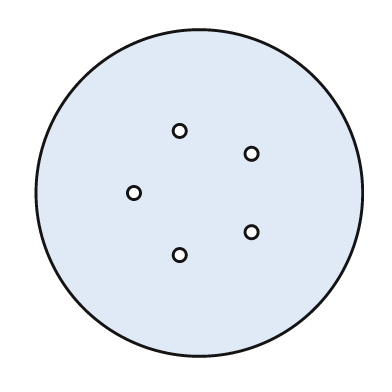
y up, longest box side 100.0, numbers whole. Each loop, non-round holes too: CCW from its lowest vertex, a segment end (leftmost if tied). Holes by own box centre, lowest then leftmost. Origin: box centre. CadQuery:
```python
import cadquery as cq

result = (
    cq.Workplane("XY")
    .moveTo(0.0, 0.0)
    .circle(50.0)
    .moveTo(-6.0, -19.0)
    .circle(2.0)
    .moveTo(16.0, -12.0)
    .circle(2.0)
    .moveTo(-20.0, 0.0)
    .circle(2.0)
    .moveTo(16.0, 12.0)
    .circle(2.0)
    .moveTo(-6.0, 19.0)
    .circle(2.0)
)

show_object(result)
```